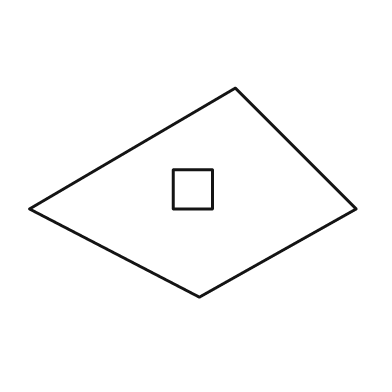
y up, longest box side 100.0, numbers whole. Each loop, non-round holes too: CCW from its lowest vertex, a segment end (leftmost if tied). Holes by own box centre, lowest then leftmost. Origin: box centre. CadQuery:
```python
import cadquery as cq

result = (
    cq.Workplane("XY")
    .moveTo(2.0, -32.0)
    .lineTo(50.0, -5.0)
    .lineTo(13.0, 32.0)
    .lineTo(-50.0, -5.0)
    .close()
    .moveTo(-6.0, -5.0)
    .lineTo(6.0, -5.0)
    .lineTo(6.0, 7.0)
    .lineTo(-6.0, 7.0)
    .close()
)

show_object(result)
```